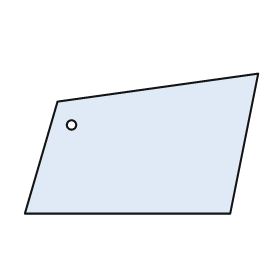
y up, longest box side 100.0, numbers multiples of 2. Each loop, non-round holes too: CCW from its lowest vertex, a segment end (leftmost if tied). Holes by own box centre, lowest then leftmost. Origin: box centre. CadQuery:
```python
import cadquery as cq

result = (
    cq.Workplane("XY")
    .moveTo(-50.0, -30.0)
    .lineTo(38.0, -30.0)
    .lineTo(50.0, 30.0)
    .lineTo(-36.0, 18.0)
    .close()
    .moveTo(-30.0, 8.0)
    .circle(2.0)
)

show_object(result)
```